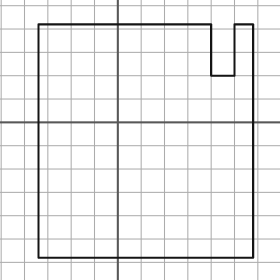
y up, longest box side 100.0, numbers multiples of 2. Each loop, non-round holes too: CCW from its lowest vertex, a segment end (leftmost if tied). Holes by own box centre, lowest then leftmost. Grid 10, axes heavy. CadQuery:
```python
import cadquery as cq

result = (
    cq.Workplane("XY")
    .moveTo(-34.0, -58.0)
    .lineTo(58.0, -58.0)
    .lineTo(58.0, 42.0)
    .lineTo(50.0, 42.0)
    .lineTo(50.0, 20.0)
    .lineTo(40.0, 20.0)
    .lineTo(40.0, 42.0)
    .lineTo(-34.0, 42.0)
    .close()
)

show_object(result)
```